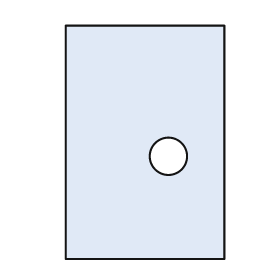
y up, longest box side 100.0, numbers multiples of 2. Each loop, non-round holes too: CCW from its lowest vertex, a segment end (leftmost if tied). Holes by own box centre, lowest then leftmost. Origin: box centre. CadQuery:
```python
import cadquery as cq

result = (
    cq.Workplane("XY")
    .moveTo(-34.0, -50.0)
    .lineTo(34.0, -50.0)
    .lineTo(34.0, 50.0)
    .lineTo(-34.0, 50.0)
    .close()
    .moveTo(10.0, -6.0)
    .circle(8.0)
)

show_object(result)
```